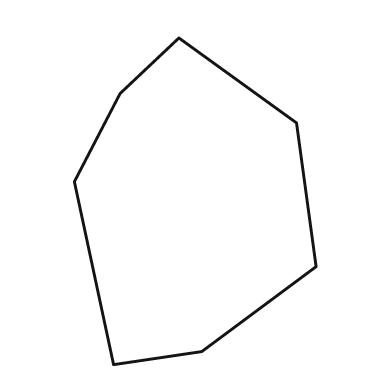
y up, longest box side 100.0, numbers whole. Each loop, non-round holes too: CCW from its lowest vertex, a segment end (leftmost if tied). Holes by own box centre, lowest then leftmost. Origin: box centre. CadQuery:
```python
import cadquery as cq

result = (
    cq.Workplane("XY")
    .moveTo(-25.0, -50.0)
    .lineTo(2.0, -46.0)
    .lineTo(37.0, -20.0)
    .lineTo(31.0, 24.0)
    .lineTo(-5.0, 50.0)
    .lineTo(-23.0, 33.0)
    .lineTo(-37.0, 6.0)
    .close()
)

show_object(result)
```